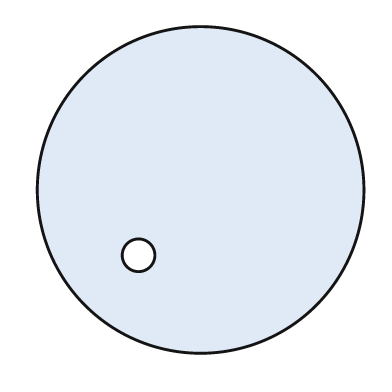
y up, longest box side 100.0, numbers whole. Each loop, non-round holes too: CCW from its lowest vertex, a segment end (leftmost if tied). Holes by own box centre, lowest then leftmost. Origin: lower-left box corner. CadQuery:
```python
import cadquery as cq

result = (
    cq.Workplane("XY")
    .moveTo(50.0, 50.0)
    .circle(50.0)
    .moveTo(31.0, 30.0)
    .circle(5.0)
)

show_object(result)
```